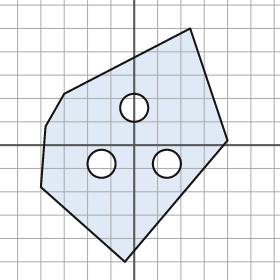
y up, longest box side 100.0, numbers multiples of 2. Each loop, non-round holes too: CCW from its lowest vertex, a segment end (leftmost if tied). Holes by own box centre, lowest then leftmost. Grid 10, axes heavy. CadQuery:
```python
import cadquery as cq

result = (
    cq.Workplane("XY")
    .moveTo(-4.0, -50.0)
    .lineTo(40.0, 2.0)
    .lineTo(24.0, 50.0)
    .lineTo(-30.0, 22.0)
    .lineTo(-38.0, 8.0)
    .lineTo(-40.0, -18.0)
    .close()
    .moveTo(-14.0, -8.0)
    .circle(6.0)
    .moveTo(14.0, -8.0)
    .circle(6.0)
    .moveTo(0.0, 16.0)
    .circle(6.0)
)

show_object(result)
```